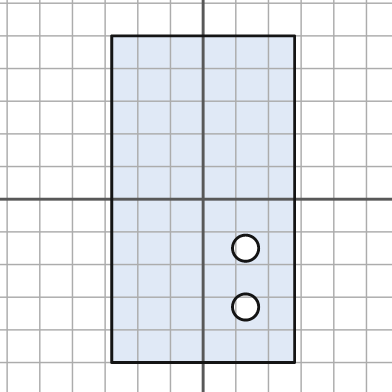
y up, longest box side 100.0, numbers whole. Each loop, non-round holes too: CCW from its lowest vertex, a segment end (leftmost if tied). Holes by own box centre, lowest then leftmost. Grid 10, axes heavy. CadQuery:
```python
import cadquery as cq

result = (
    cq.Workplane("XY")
    .moveTo(-28.0, -50.0)
    .lineTo(28.0, -50.0)
    .lineTo(28.0, 50.0)
    .lineTo(-28.0, 50.0)
    .close()
    .moveTo(13.0, -33.0)
    .circle(4.0)
    .moveTo(13.0, -15.0)
    .circle(4.0)
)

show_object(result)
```